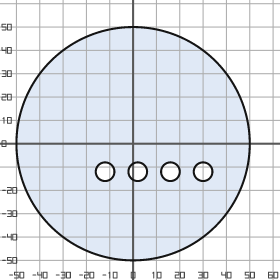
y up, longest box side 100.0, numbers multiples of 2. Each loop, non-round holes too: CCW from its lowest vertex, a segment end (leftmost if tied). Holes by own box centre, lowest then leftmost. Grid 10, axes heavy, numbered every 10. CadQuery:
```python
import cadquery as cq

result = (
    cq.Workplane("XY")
    .moveTo(0.0, 0.0)
    .circle(50.0)
    .moveTo(-12.0, -12.0)
    .circle(4.0)
    .moveTo(2.0, -12.0)
    .circle(4.0)
    .moveTo(16.0, -12.0)
    .circle(4.0)
    .moveTo(30.0, -12.0)
    .circle(4.0)
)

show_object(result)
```